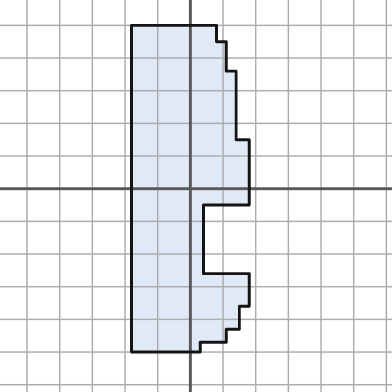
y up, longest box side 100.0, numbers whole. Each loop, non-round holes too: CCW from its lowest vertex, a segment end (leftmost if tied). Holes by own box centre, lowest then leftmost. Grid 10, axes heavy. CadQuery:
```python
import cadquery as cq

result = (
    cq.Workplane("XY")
    .moveTo(-18.0, -50.0)
    .lineTo(3.0, -50.0)
    .lineTo(3.0, -47.0)
    .lineTo(11.0, -47.0)
    .lineTo(11.0, -43.0)
    .lineTo(15.0, -43.0)
    .lineTo(15.0, -36.0)
    .lineTo(18.0, -36.0)
    .lineTo(18.0, -26.0)
    .lineTo(4.0, -26.0)
    .lineTo(4.0, -5.0)
    .lineTo(18.0, -5.0)
    .lineTo(18.0, 15.0)
    .lineTo(14.0, 15.0)
    .lineTo(14.0, 36.0)
    .lineTo(11.0, 36.0)
    .lineTo(11.0, 45.0)
    .lineTo(8.0, 45.0)
    .lineTo(8.0, 50.0)
    .lineTo(-18.0, 50.0)
    .close()
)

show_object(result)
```